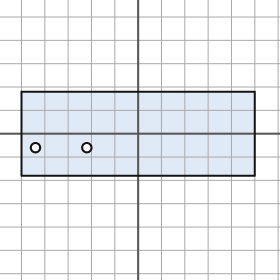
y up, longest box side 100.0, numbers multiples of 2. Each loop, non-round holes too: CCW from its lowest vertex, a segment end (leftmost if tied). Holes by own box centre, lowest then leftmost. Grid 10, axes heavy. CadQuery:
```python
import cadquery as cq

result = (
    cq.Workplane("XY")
    .moveTo(-50.0, -18.0)
    .lineTo(50.0, -18.0)
    .lineTo(50.0, 18.0)
    .lineTo(-50.0, 18.0)
    .close()
    .moveTo(-44.0, -6.0)
    .circle(2.0)
    .moveTo(-22.0, -6.0)
    .circle(2.0)
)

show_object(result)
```